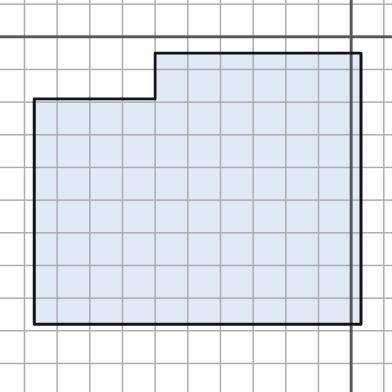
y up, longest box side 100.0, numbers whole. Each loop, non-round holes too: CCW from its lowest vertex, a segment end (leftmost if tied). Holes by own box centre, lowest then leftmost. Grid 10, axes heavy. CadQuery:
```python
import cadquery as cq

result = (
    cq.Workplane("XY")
    .moveTo(-97.0, -88.0)
    .lineTo(3.0, -88.0)
    .lineTo(3.0, -5.0)
    .lineTo(-60.0, -5.0)
    .lineTo(-60.0, -19.0)
    .lineTo(-97.0, -19.0)
    .close()
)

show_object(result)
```